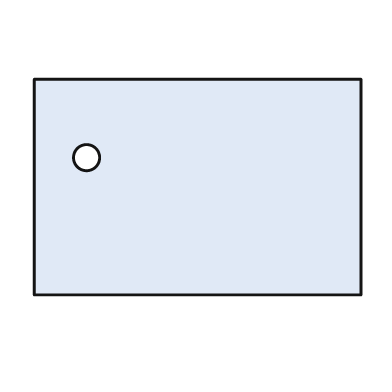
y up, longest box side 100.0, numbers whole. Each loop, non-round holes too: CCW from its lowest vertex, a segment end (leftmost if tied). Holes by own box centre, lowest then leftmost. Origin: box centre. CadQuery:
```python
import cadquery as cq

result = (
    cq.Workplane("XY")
    .moveTo(-50.0, -33.0)
    .lineTo(50.0, -33.0)
    .lineTo(50.0, 33.0)
    .lineTo(-50.0, 33.0)
    .close()
    .moveTo(-34.0, 9.0)
    .circle(4.0)
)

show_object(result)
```